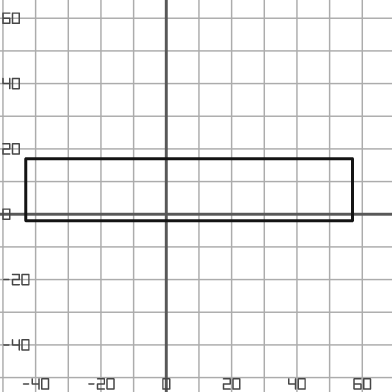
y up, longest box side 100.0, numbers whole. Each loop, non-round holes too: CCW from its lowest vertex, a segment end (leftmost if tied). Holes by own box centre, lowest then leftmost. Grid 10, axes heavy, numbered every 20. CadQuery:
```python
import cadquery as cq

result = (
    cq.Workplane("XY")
    .moveTo(-43.0, -2.0)
    .lineTo(57.0, -2.0)
    .lineTo(57.0, 17.0)
    .lineTo(-43.0, 17.0)
    .close()
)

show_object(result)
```